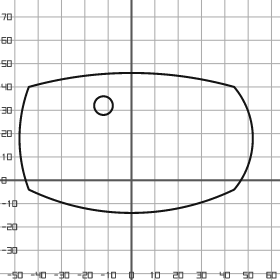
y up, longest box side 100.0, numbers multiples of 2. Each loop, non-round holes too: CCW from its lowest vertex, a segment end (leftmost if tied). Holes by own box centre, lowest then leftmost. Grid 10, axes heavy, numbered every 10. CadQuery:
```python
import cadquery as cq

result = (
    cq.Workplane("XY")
    .moveTo(-44.0, -4.0)
    .threePointArc((0.0, -14.0), (44.0, -4.0))
    .threePointArc((52.0, 18.0), (44.0, 40.0))
    .threePointArc((0.0, 46.0), (-44.0, 40.0))
    .threePointArc((-48.0, 18.0), (-44.0, -4.0))
    .close()
    .moveTo(-12.0, 32.0)
    .circle(4.0)
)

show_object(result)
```